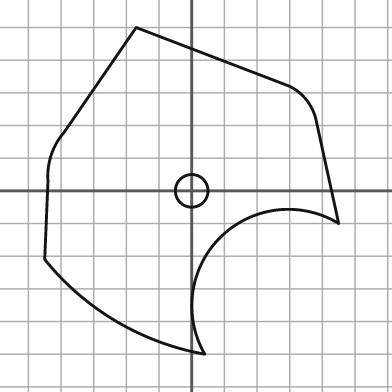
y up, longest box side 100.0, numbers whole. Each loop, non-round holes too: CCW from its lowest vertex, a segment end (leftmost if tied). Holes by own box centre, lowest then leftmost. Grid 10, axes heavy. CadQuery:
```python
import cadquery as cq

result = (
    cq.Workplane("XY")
    .moveTo(4.0, -50.0)
    .threePointArc((9.0, -14.0), (45.0, -10.0))
    .lineTo(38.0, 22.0)
    .threePointArc((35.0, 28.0), (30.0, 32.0))
    .lineTo(-17.0, 50.0)
    .lineTo(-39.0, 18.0)
    .threePointArc((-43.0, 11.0), (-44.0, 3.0))
    .lineTo(-45.0, -21.0)
    .threePointArc((-23.0, -40.0), (4.0, -50.0))
    .close()
    .moveTo(0.0, 0.0)
    .circle(5.0)
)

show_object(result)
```